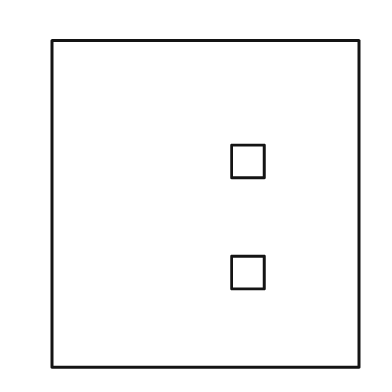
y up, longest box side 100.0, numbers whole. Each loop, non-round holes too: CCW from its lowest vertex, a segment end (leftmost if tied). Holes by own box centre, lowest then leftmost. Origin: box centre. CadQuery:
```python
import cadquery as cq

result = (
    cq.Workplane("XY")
    .moveTo(-47.0, -50.0)
    .lineTo(47.0, -50.0)
    .lineTo(47.0, 50.0)
    .lineTo(-47.0, 50.0)
    .close()
    .moveTo(8.0, -26.0)
    .lineTo(18.0, -26.0)
    .lineTo(18.0, -16.0)
    .lineTo(8.0, -16.0)
    .close()
    .moveTo(8.0, 8.0)
    .lineTo(18.0, 8.0)
    .lineTo(18.0, 18.0)
    .lineTo(8.0, 18.0)
    .close()
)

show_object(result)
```